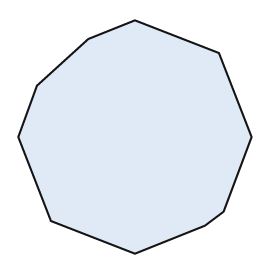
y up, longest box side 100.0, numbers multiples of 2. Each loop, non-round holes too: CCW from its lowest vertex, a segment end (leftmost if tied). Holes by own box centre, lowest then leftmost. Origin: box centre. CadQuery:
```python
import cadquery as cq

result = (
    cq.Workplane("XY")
    .moveTo(0.0, -50.0)
    .lineTo(30.0, -38.0)
    .lineTo(38.0, -32.0)
    .lineTo(50.0, 0.0)
    .lineTo(36.0, 36.0)
    .lineTo(0.0, 50.0)
    .lineTo(-20.0, 42.0)
    .lineTo(-42.0, 22.0)
    .lineTo(-50.0, 0.0)
    .lineTo(-36.0, -36.0)
    .close()
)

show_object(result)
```